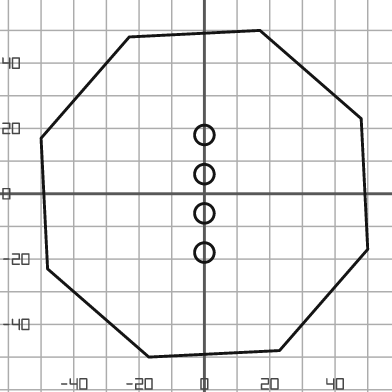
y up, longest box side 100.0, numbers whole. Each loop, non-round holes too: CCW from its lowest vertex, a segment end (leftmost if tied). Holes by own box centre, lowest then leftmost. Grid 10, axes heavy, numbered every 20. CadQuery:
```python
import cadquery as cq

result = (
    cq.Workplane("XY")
    .moveTo(-17.0, -50.0)
    .lineTo(23.0, -48.0)
    .lineTo(50.0, -17.0)
    .lineTo(48.0, 23.0)
    .lineTo(17.0, 50.0)
    .lineTo(-23.0, 48.0)
    .lineTo(-50.0, 17.0)
    .lineTo(-48.0, -23.0)
    .close()
    .moveTo(0.0, -18.0)
    .circle(3.0)
    .moveTo(0.0, -6.0)
    .circle(3.0)
    .moveTo(0.0, 6.0)
    .circle(3.0)
    .moveTo(0.0, 18.0)
    .circle(3.0)
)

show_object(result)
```